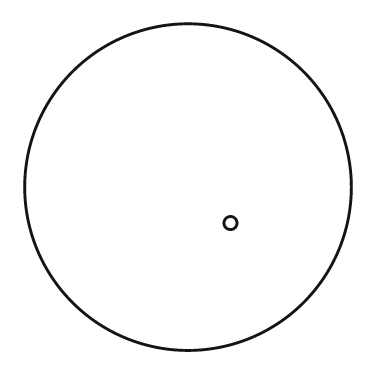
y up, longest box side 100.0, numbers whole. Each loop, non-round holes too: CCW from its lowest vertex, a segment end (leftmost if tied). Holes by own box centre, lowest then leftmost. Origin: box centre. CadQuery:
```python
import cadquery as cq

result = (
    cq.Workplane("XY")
    .moveTo(0.0, 0.0)
    .circle(50.0)
    .moveTo(13.0, -11.0)
    .circle(2.0)
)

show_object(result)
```